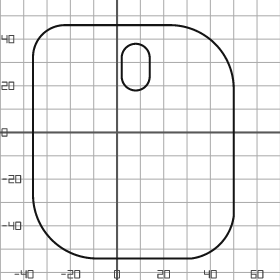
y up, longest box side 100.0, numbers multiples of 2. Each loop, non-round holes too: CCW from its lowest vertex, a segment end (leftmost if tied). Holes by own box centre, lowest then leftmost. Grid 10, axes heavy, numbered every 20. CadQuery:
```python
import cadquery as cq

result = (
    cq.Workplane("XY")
    .moveTo(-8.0, -54.0)
    .lineTo(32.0, -54.0)
    .threePointArc((44.0, -48.0), (50.0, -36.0))
    .lineTo(50.0, 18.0)
    .threePointArc((42.0, 38.0), (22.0, 46.0))
    .lineTo(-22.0, 46.0)
    .threePointArc((-32.0, 42.0), (-36.0, 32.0))
    .lineTo(-36.0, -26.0)
    .threePointArc((-28.0, -46.0), (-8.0, -54.0))
    .close()
    .moveTo(2.0, 24.0)
    .threePointArc((8.0, 18.0), (14.0, 24.0))
    .lineTo(14.0, 32.0)
    .threePointArc((8.0, 38.0), (2.0, 32.0))
    .close()
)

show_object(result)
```